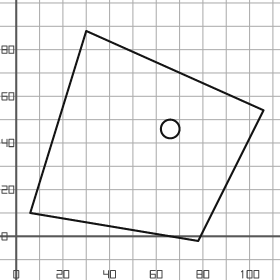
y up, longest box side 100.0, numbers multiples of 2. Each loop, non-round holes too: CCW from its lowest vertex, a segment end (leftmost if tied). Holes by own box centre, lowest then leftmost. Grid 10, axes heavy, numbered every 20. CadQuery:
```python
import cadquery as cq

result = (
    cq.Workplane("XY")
    .moveTo(78.0, -2.0)
    .lineTo(106.0, 54.0)
    .lineTo(30.0, 88.0)
    .lineTo(6.0, 10.0)
    .close()
    .moveTo(66.0, 46.0)
    .circle(4.0)
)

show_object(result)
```